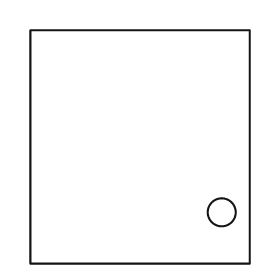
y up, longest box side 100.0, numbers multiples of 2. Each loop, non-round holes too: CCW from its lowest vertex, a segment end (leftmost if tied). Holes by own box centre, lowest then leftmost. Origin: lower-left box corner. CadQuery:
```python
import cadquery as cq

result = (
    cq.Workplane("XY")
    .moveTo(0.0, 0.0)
    .lineTo(94.0, 0.0)
    .lineTo(94.0, 100.0)
    .lineTo(0.0, 100.0)
    .close()
    .moveTo(82.0, 22.0)
    .circle(6.0)
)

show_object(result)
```